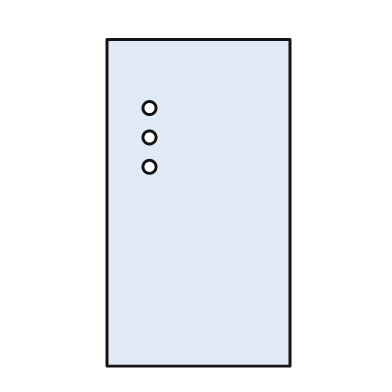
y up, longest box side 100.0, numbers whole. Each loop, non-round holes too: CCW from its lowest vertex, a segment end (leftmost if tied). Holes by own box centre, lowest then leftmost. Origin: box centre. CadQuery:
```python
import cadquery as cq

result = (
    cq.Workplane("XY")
    .moveTo(-28.0, -50.0)
    .lineTo(28.0, -50.0)
    .lineTo(28.0, 50.0)
    .lineTo(-28.0, 50.0)
    .close()
    .moveTo(-15.0, 11.0)
    .circle(2.0)
    .moveTo(-15.0, 20.0)
    .circle(2.0)
    .moveTo(-15.0, 29.0)
    .circle(2.0)
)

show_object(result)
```